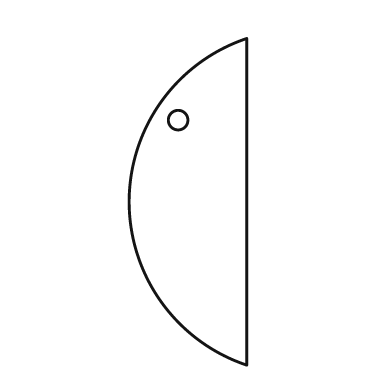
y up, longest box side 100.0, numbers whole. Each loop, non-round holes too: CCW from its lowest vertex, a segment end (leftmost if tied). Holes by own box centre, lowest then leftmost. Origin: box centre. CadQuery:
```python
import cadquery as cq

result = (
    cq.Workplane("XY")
    .moveTo(18.0, -50.0)
    .lineTo(18.0, 50.0)
    .threePointArc((-18.0, 0.0), (18.0, -50.0))
    .close()
    .moveTo(-3.0, 25.0)
    .circle(3.0)
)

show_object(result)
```